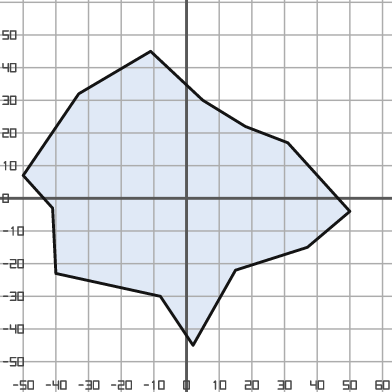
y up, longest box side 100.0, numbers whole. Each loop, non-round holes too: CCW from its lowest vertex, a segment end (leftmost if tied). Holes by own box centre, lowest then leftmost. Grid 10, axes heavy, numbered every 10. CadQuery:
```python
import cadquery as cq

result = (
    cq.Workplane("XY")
    .moveTo(2.0, -45.0)
    .lineTo(15.0, -22.0)
    .lineTo(37.0, -15.0)
    .lineTo(50.0, -4.0)
    .lineTo(31.0, 17.0)
    .lineTo(18.0, 22.0)
    .lineTo(5.0, 30.0)
    .lineTo(-11.0, 45.0)
    .lineTo(-33.0, 32.0)
    .lineTo(-50.0, 7.0)
    .lineTo(-41.0, -3.0)
    .lineTo(-40.0, -23.0)
    .lineTo(-8.0, -30.0)
    .close()
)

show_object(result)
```